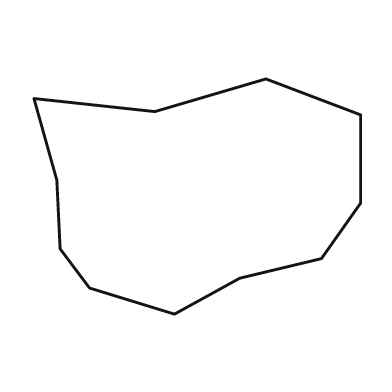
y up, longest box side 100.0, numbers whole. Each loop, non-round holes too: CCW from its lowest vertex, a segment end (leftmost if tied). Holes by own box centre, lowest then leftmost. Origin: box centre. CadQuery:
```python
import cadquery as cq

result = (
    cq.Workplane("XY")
    .moveTo(-7.0, -36.0)
    .lineTo(13.0, -25.0)
    .lineTo(38.0, -19.0)
    .lineTo(50.0, -2.0)
    .lineTo(50.0, 25.0)
    .lineTo(21.0, 36.0)
    .lineTo(-13.0, 26.0)
    .lineTo(-50.0, 30.0)
    .lineTo(-43.0, 5.0)
    .lineTo(-42.0, -16.0)
    .lineTo(-33.0, -28.0)
    .close()
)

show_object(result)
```